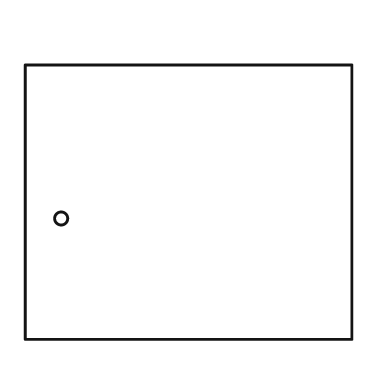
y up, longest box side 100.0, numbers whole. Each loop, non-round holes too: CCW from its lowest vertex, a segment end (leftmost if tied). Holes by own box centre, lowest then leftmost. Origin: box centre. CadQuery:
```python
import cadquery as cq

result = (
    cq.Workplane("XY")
    .moveTo(-50.0, -42.0)
    .lineTo(50.0, -42.0)
    .lineTo(50.0, 42.0)
    .lineTo(-50.0, 42.0)
    .close()
    .moveTo(-39.0, -5.0)
    .circle(2.0)
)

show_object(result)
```